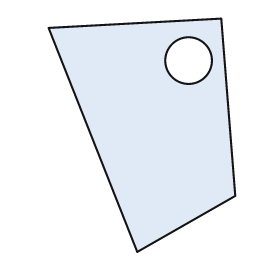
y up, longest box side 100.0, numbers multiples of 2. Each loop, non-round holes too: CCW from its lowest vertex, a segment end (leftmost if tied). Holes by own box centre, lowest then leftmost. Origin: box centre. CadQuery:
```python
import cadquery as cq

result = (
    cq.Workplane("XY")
    .moveTo(-2.0, -50.0)
    .lineTo(40.0, -26.0)
    .lineTo(34.0, 50.0)
    .lineTo(-40.0, 46.0)
    .close()
    .moveTo(20.0, 32.0)
    .circle(10.0)
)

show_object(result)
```